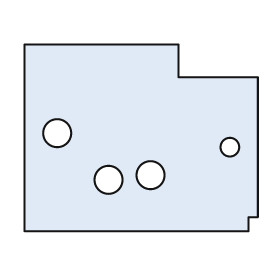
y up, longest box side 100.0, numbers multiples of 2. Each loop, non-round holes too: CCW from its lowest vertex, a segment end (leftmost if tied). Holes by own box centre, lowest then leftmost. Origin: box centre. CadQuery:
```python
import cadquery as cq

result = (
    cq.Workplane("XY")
    .moveTo(-50.0, -40.0)
    .lineTo(46.0, -40.0)
    .lineTo(46.0, -34.0)
    .lineTo(50.0, -34.0)
    .lineTo(50.0, 26.0)
    .lineTo(16.0, 26.0)
    .lineTo(16.0, 40.0)
    .lineTo(-50.0, 40.0)
    .close()
    .moveTo(-14.0, -18.0)
    .circle(6.0)
    .moveTo(4.0, -16.0)
    .circle(6.0)
    .moveTo(38.0, -4.0)
    .circle(4.0)
    .moveTo(-36.0, 2.0)
    .circle(6.0)
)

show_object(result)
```